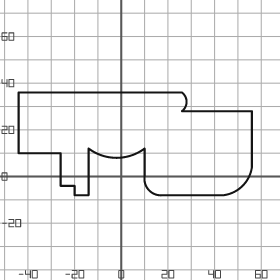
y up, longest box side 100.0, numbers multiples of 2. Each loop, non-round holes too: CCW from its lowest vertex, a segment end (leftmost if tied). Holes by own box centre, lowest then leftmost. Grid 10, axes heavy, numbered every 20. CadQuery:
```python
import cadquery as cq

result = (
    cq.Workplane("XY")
    .moveTo(-20.0, -8.0)
    .lineTo(-14.0, -8.0)
    .lineTo(-14.0, 12.0)
    .threePointArc((-2.0, 8.0), (10.0, 12.0))
    .lineTo(10.0, 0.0)
    .threePointArc((12.0, -6.0), (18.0, -8.0))
    .lineTo(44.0, -8.0)
    .threePointArc((52.0, -4.0), (56.0, 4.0))
    .lineTo(56.0, 28.0)
    .lineTo(26.0, 28.0)
    .threePointArc((28.0, 32.0), (26.0, 36.0))
    .lineTo(-44.0, 36.0)
    .lineTo(-44.0, 10.0)
    .lineTo(-26.0, 10.0)
    .lineTo(-26.0, -4.0)
    .lineTo(-20.0, -4.0)
    .close()
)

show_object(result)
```